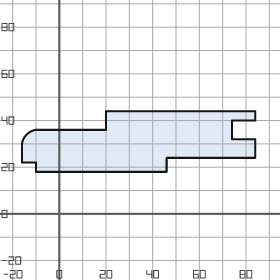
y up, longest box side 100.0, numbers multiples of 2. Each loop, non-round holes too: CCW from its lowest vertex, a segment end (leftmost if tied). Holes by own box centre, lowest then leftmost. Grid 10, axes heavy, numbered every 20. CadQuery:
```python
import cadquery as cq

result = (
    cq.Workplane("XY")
    .moveTo(-10.0, 18.0)
    .lineTo(46.0, 18.0)
    .lineTo(46.0, 24.0)
    .lineTo(84.0, 24.0)
    .lineTo(84.0, 32.0)
    .lineTo(74.0, 32.0)
    .lineTo(74.0, 40.0)
    .lineTo(84.0, 40.0)
    .lineTo(84.0, 44.0)
    .lineTo(20.0, 44.0)
    .lineTo(20.0, 36.0)
    .lineTo(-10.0, 36.0)
    .threePointArc((-14.0, 34.0), (-16.0, 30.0))
    .lineTo(-16.0, 22.0)
    .lineTo(-10.0, 22.0)
    .close()
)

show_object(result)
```